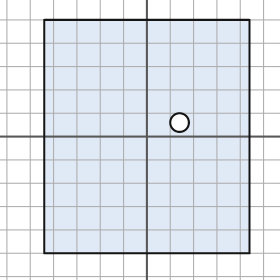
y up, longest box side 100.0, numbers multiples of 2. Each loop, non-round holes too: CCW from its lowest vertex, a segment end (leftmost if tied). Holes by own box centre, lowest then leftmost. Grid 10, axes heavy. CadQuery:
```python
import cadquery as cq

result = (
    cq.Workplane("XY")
    .moveTo(-44.0, -50.0)
    .lineTo(44.0, -50.0)
    .lineTo(44.0, 50.0)
    .lineTo(-44.0, 50.0)
    .close()
    .moveTo(14.0, 6.0)
    .circle(4.0)
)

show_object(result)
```